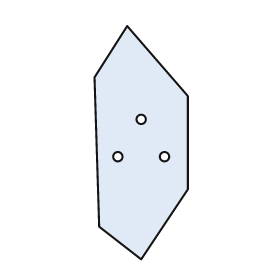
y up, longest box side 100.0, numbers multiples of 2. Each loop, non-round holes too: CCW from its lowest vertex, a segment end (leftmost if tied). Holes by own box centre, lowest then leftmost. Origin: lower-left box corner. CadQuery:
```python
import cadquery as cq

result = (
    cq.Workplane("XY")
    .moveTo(20.0, 0.0)
    .lineTo(40.0, 30.0)
    .lineTo(40.0, 70.0)
    .lineTo(14.0, 100.0)
    .lineTo(0.0, 78.0)
    .lineTo(2.0, 14.0)
    .close()
    .moveTo(10.0, 44.0)
    .circle(2.0)
    .moveTo(30.0, 44.0)
    .circle(2.0)
    .moveTo(20.0, 60.0)
    .circle(2.0)
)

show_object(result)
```